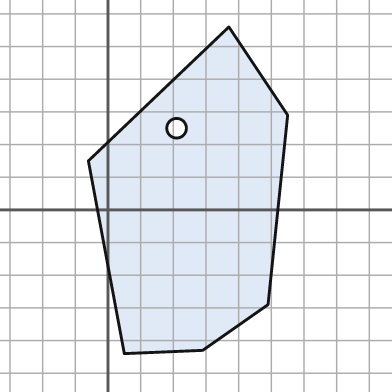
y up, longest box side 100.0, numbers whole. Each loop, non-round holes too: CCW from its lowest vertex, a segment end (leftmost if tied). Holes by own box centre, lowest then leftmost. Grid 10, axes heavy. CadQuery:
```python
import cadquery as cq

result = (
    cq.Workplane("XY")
    .moveTo(5.0, -44.0)
    .lineTo(29.0, -43.0)
    .lineTo(49.0, -29.0)
    .lineTo(55.0, 29.0)
    .lineTo(37.0, 56.0)
    .lineTo(-6.0, 15.0)
    .close()
    .moveTo(21.0, 25.0)
    .circle(3.0)
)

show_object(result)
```